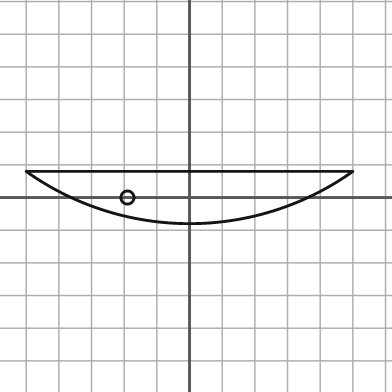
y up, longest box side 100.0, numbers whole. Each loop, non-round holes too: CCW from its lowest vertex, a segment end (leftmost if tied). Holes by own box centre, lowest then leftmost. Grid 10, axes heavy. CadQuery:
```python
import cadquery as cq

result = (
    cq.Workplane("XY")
    .moveTo(-50.0, 8.0)
    .threePointArc((0.0, -8.0), (50.0, 8.0))
    .close()
    .moveTo(-19.0, 0.0)
    .circle(2.0)
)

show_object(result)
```